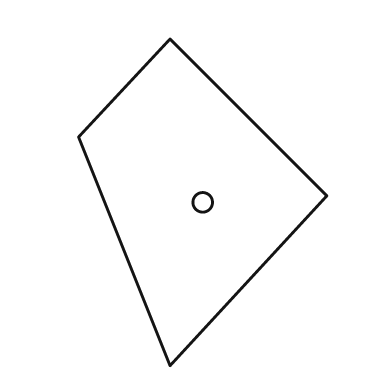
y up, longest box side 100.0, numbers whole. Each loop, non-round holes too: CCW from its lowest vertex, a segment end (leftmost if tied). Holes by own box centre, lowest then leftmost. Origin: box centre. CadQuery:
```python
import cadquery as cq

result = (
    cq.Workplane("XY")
    .moveTo(-10.0, -50.0)
    .lineTo(38.0, 2.0)
    .lineTo(-10.0, 50.0)
    .lineTo(-38.0, 20.0)
    .close()
    .moveTo(0.0, 0.0)
    .circle(3.0)
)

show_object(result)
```